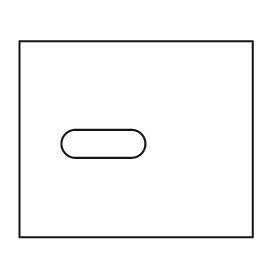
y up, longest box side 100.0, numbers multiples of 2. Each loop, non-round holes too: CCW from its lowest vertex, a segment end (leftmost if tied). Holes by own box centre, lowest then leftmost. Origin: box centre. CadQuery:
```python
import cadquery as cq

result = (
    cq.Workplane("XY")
    .moveTo(-50.0, -42.0)
    .lineTo(50.0, -42.0)
    .lineTo(50.0, 42.0)
    .lineTo(-50.0, 42.0)
    .close()
    .moveTo(-26.0, -8.0)
    .lineTo(-2.0, -8.0)
    .threePointArc((4.0, -2.0), (-2.0, 4.0))
    .lineTo(-26.0, 4.0)
    .threePointArc((-32.0, -2.0), (-26.0, -8.0))
    .close()
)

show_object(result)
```